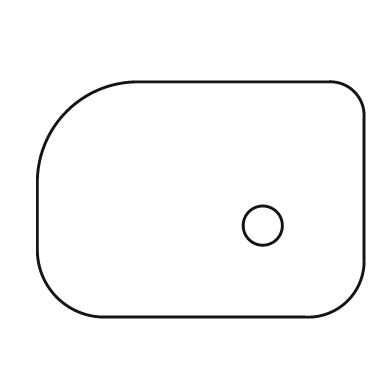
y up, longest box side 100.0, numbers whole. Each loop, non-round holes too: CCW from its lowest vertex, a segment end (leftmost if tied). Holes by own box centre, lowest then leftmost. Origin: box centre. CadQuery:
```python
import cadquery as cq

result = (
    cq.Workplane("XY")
    .moveTo(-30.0, -36.0)
    .lineTo(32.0, -36.0)
    .threePointArc((45.0, -31.0), (50.0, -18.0))
    .lineTo(50.0, 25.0)
    .threePointArc((47.0, 33.0), (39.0, 36.0))
    .lineTo(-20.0, 36.0)
    .threePointArc((-41.0, 27.0), (-50.0, 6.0))
    .lineTo(-50.0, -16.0)
    .threePointArc((-44.0, -30.0), (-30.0, -36.0))
    .close()
    .moveTo(19.0, -8.0)
    .circle(6.0)
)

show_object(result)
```